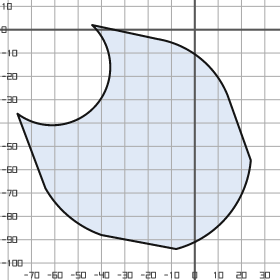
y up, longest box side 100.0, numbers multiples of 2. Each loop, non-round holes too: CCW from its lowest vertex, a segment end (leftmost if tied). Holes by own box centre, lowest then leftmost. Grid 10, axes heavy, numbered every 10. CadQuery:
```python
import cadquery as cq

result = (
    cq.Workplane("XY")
    .moveTo(-8.0, -94.0)
    .threePointArc((14.0, -80.0), (24.0, -56.0))
    .lineTo(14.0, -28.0)
    .threePointArc((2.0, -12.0), (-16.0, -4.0))
    .lineTo(-44.0, 2.0)
    .threePointArc((-42.0, -32.0), (-76.0, -36.0))
    .lineTo(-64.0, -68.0)
    .threePointArc((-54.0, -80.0), (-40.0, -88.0))
    .close()
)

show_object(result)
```